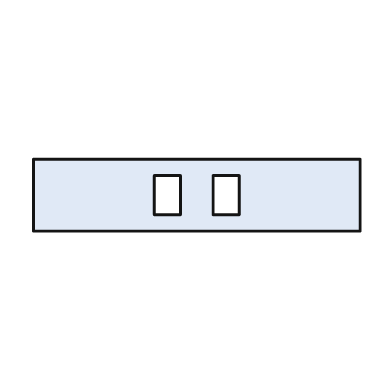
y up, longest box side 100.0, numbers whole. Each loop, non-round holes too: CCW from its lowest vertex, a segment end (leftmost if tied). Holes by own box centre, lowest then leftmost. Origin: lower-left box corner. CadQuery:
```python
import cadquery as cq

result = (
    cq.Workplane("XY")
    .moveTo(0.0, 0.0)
    .lineTo(100.0, 0.0)
    .lineTo(100.0, 22.0)
    .lineTo(0.0, 22.0)
    .close()
    .moveTo(37.0, 5.0)
    .lineTo(45.0, 5.0)
    .lineTo(45.0, 17.0)
    .lineTo(37.0, 17.0)
    .close()
    .moveTo(55.0, 5.0)
    .lineTo(63.0, 5.0)
    .lineTo(63.0, 17.0)
    .lineTo(55.0, 17.0)
    .close()
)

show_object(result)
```